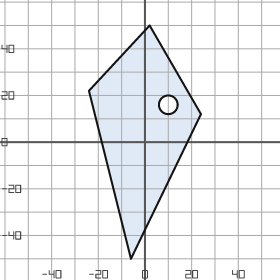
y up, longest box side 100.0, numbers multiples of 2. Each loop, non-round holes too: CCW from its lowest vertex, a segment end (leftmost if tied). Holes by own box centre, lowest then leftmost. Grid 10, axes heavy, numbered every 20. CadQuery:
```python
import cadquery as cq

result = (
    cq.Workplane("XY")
    .moveTo(-6.0, -50.0)
    .lineTo(24.0, 12.0)
    .lineTo(2.0, 50.0)
    .lineTo(-24.0, 22.0)
    .close()
    .moveTo(10.0, 16.0)
    .circle(4.0)
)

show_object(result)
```